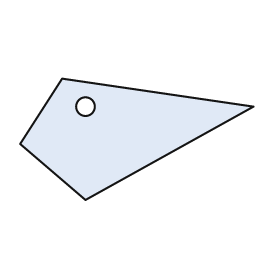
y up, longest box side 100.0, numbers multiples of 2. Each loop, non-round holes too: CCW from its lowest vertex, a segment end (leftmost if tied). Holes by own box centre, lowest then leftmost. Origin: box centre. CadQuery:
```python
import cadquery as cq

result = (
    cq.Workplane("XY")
    .moveTo(-22.0, -26.0)
    .lineTo(50.0, 14.0)
    .lineTo(-32.0, 26.0)
    .lineTo(-50.0, -2.0)
    .close()
    .moveTo(-22.0, 14.0)
    .circle(4.0)
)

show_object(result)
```